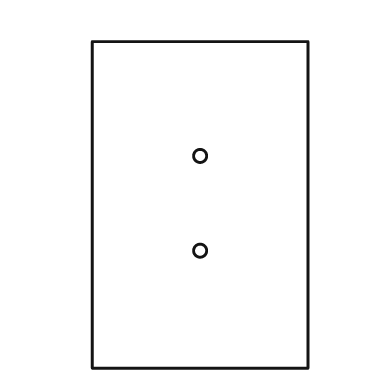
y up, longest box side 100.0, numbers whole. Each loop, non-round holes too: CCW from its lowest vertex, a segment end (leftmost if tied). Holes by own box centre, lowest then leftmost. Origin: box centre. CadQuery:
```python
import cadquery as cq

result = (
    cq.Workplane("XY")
    .moveTo(-33.0, -50.0)
    .lineTo(33.0, -50.0)
    .lineTo(33.0, 50.0)
    .lineTo(-33.0, 50.0)
    .close()
    .moveTo(0.0, -14.0)
    .circle(2.0)
    .moveTo(0.0, 15.0)
    .circle(2.0)
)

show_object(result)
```